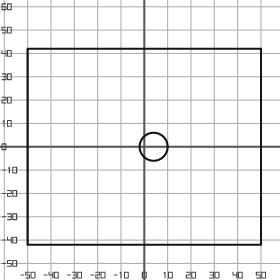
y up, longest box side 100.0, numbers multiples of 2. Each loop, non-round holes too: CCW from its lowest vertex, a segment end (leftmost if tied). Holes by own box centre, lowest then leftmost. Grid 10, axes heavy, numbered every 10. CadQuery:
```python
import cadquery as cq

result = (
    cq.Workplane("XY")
    .moveTo(-50.0, -42.0)
    .lineTo(50.0, -42.0)
    .lineTo(50.0, 42.0)
    .lineTo(-50.0, 42.0)
    .close()
    .moveTo(4.0, 0.0)
    .circle(6.0)
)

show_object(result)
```